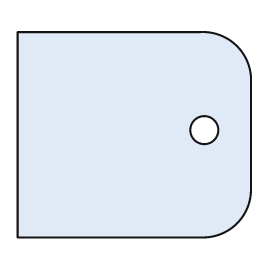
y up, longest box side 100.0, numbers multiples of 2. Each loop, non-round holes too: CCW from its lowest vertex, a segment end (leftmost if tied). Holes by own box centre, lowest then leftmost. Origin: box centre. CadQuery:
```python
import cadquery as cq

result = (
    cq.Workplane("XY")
    .moveTo(-50.0, -44.0)
    .lineTo(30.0, -44.0)
    .threePointArc((44.0, -38.0), (50.0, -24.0))
    .lineTo(50.0, 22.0)
    .threePointArc((44.0, 38.0), (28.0, 44.0))
    .lineTo(-50.0, 44.0)
    .close()
    .moveTo(30.0, 2.0)
    .circle(6.0)
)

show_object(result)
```